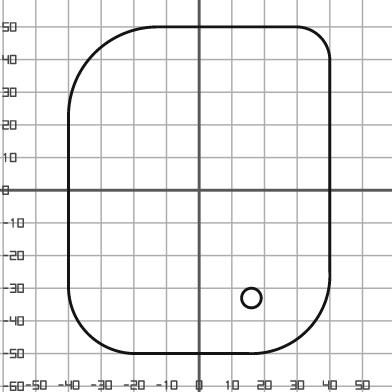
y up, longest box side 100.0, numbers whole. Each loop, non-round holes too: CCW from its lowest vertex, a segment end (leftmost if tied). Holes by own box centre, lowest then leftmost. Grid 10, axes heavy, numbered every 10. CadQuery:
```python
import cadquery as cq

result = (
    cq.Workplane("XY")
    .moveTo(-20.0, -50.0)
    .lineTo(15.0, -50.0)
    .threePointArc((33.0, -43.0), (40.0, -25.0))
    .lineTo(40.0, 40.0)
    .threePointArc((37.0, 47.0), (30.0, 50.0))
    .lineTo(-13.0, 50.0)
    .threePointArc((-32.0, 42.0), (-40.0, 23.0))
    .lineTo(-40.0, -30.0)
    .threePointArc((-34.0, -44.0), (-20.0, -50.0))
    .close()
    .moveTo(16.0, -33.0)
    .circle(3.0)
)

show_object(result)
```